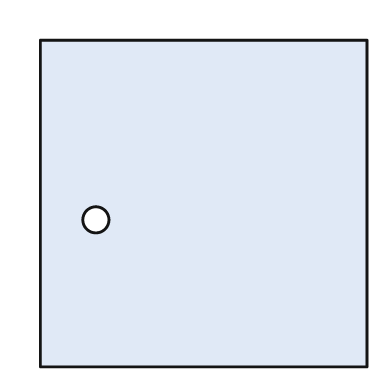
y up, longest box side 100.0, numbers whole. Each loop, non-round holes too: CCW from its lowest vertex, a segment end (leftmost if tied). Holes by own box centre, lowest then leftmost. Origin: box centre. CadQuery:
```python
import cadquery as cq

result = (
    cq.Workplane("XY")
    .moveTo(-50.0, -50.0)
    .lineTo(50.0, -50.0)
    .lineTo(50.0, 50.0)
    .lineTo(-50.0, 50.0)
    .close()
    .moveTo(-33.0, -5.0)
    .circle(4.0)
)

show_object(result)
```